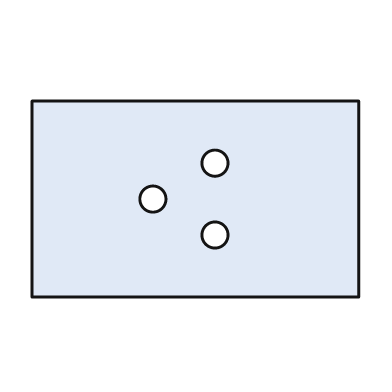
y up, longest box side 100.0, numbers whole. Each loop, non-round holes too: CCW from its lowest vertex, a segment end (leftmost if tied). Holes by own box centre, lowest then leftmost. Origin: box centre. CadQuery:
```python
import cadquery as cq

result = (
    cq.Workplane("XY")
    .moveTo(-50.0, -30.0)
    .lineTo(50.0, -30.0)
    .lineTo(50.0, 30.0)
    .lineTo(-50.0, 30.0)
    .close()
    .moveTo(6.0, -11.0)
    .circle(4.0)
    .moveTo(-13.0, 0.0)
    .circle(4.0)
    .moveTo(6.0, 11.0)
    .circle(4.0)
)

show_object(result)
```